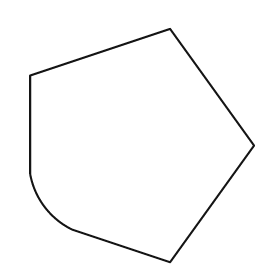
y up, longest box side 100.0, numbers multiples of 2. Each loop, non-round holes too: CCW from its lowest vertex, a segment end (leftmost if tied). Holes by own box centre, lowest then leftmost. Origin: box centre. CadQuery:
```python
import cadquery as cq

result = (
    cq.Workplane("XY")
    .moveTo(12.0, -50.0)
    .lineTo(48.0, 0.0)
    .lineTo(12.0, 50.0)
    .lineTo(-48.0, 30.0)
    .lineTo(-48.0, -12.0)
    .threePointArc((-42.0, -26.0), (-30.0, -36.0))
    .close()
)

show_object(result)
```